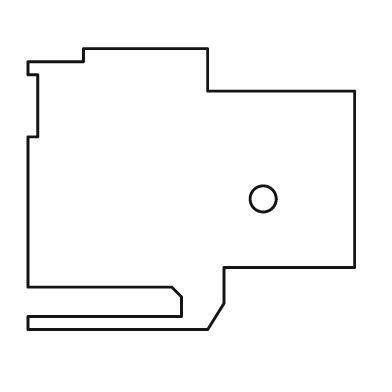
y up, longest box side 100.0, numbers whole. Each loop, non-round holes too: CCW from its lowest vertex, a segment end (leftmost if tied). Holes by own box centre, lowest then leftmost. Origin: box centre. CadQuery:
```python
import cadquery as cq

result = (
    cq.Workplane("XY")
    .moveTo(-50.0, -43.0)
    .lineTo(5.0, -43.0)
    .lineTo(10.0, -35.0)
    .lineTo(10.0, -24.0)
    .lineTo(50.0, -24.0)
    .lineTo(50.0, 30.0)
    .lineTo(5.0, 30.0)
    .lineTo(5.0, 43.0)
    .lineTo(-33.0, 43.0)
    .lineTo(-33.0, 39.0)
    .lineTo(-50.0, 39.0)
    .lineTo(-50.0, 35.0)
    .lineTo(-47.0, 35.0)
    .lineTo(-47.0, 16.0)
    .lineTo(-50.0, 16.0)
    .lineTo(-50.0, -30.0)
    .lineTo(-6.0, -30.0)
    .lineTo(-3.0, -33.0)
    .lineTo(-3.0, -39.0)
    .lineTo(-50.0, -39.0)
    .close()
    .moveTo(22.0, -3.0)
    .circle(4.0)
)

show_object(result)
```